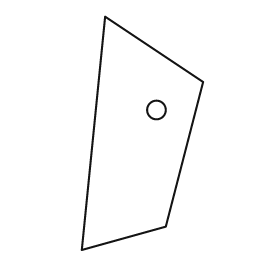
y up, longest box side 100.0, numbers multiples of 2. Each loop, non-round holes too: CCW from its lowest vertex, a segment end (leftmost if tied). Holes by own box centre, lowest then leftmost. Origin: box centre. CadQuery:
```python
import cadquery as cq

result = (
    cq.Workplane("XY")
    .moveTo(-26.0, -50.0)
    .lineTo(10.0, -40.0)
    .lineTo(26.0, 22.0)
    .lineTo(-16.0, 50.0)
    .close()
    .moveTo(6.0, 10.0)
    .circle(4.0)
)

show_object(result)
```